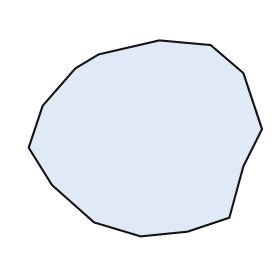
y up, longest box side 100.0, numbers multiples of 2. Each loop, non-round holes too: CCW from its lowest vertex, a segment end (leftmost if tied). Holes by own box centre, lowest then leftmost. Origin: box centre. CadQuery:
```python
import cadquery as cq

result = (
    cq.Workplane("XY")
    .moveTo(-2.0, -42.0)
    .lineTo(18.0, -40.0)
    .lineTo(36.0, -34.0)
    .lineTo(42.0, -12.0)
    .lineTo(50.0, 4.0)
    .lineTo(42.0, 28.0)
    .lineTo(28.0, 40.0)
    .lineTo(6.0, 42.0)
    .lineTo(-20.0, 36.0)
    .lineTo(-30.0, 30.0)
    .lineTo(-44.0, 14.0)
    .lineTo(-50.0, -4.0)
    .lineTo(-40.0, -20.0)
    .lineTo(-22.0, -36.0)
    .close()
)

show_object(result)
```